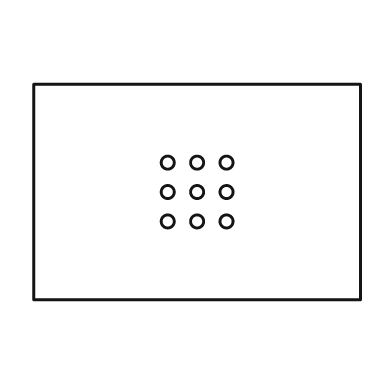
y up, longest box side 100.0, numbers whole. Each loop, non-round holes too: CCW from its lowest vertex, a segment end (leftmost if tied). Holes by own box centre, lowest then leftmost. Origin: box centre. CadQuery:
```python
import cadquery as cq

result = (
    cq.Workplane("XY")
    .moveTo(-50.0, -33.0)
    .lineTo(50.0, -33.0)
    .lineTo(50.0, 33.0)
    .lineTo(-50.0, 33.0)
    .close()
    .moveTo(-9.0, -9.0)
    .circle(2.0)
    .moveTo(0.0, -9.0)
    .circle(2.0)
    .moveTo(9.0, -9.0)
    .circle(2.0)
    .moveTo(-9.0, 0.0)
    .circle(2.0)
    .moveTo(0.0, 0.0)
    .circle(2.0)
    .moveTo(9.0, 0.0)
    .circle(2.0)
    .moveTo(-9.0, 9.0)
    .circle(2.0)
    .moveTo(0.0, 9.0)
    .circle(2.0)
    .moveTo(9.0, 9.0)
    .circle(2.0)
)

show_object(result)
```